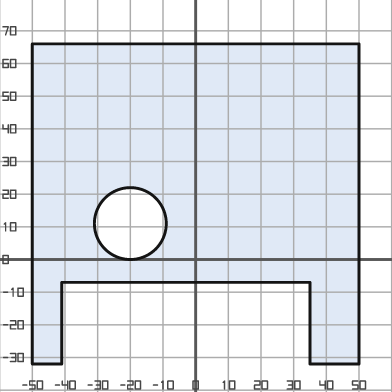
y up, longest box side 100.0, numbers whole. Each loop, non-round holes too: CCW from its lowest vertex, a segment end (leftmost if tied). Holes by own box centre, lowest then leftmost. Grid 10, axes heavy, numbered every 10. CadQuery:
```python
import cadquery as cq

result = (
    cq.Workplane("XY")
    .moveTo(-50.0, -32.0)
    .lineTo(-41.0, -32.0)
    .lineTo(-41.0, -7.0)
    .lineTo(35.0, -7.0)
    .lineTo(35.0, -32.0)
    .lineTo(50.0, -32.0)
    .lineTo(50.0, 66.0)
    .lineTo(-50.0, 66.0)
    .close()
    .moveTo(-20.0, 11.0)
    .circle(11.0)
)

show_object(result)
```